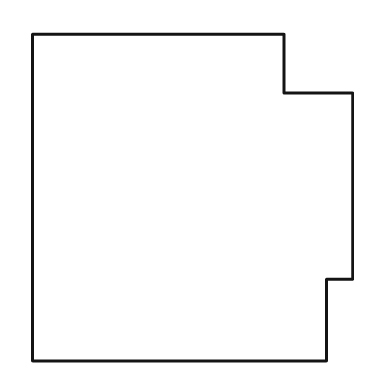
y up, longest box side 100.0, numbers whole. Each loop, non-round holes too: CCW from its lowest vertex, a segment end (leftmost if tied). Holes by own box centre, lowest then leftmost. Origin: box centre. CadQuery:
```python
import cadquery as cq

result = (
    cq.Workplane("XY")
    .moveTo(-49.0, -50.0)
    .lineTo(41.0, -50.0)
    .lineTo(41.0, -25.0)
    .lineTo(49.0, -25.0)
    .lineTo(49.0, 32.0)
    .lineTo(28.0, 32.0)
    .lineTo(28.0, 50.0)
    .lineTo(-49.0, 50.0)
    .close()
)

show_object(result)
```